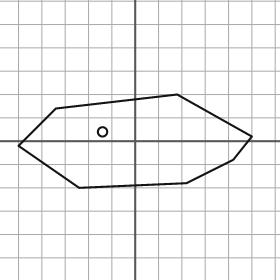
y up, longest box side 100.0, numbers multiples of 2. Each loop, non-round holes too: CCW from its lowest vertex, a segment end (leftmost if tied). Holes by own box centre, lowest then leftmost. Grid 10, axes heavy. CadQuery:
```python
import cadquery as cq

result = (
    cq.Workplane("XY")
    .moveTo(-24.0, -20.0)
    .lineTo(22.0, -18.0)
    .lineTo(42.0, -8.0)
    .lineTo(50.0, 2.0)
    .lineTo(18.0, 20.0)
    .lineTo(-34.0, 14.0)
    .lineTo(-50.0, -2.0)
    .close()
    .moveTo(-14.0, 4.0)
    .circle(2.0)
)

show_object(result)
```